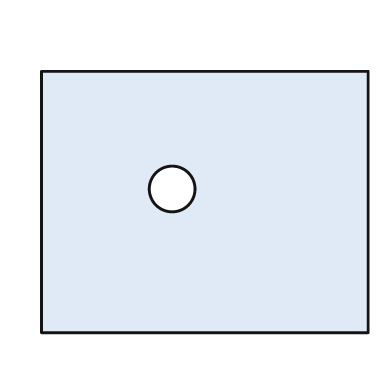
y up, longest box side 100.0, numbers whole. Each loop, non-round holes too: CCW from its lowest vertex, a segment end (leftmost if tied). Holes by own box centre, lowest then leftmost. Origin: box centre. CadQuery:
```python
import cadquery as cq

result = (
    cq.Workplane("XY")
    .moveTo(-50.0, -40.0)
    .lineTo(50.0, -40.0)
    .lineTo(50.0, 40.0)
    .lineTo(-50.0, 40.0)
    .close()
    .moveTo(-10.0, 4.0)
    .circle(7.0)
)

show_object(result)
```